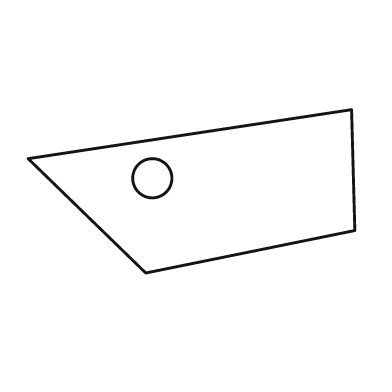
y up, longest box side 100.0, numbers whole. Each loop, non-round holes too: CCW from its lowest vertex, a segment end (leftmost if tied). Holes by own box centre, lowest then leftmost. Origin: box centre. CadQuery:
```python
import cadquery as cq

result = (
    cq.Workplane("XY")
    .moveTo(-14.0, -25.0)
    .lineTo(50.0, -12.0)
    .lineTo(49.0, 25.0)
    .lineTo(-50.0, 10.0)
    .close()
    .moveTo(-12.0, 4.0)
    .circle(6.0)
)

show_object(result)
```